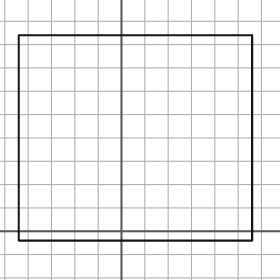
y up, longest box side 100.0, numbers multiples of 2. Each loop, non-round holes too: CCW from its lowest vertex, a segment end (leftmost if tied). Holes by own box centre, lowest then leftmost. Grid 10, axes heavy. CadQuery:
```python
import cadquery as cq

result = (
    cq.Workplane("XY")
    .moveTo(-44.0, -4.0)
    .lineTo(56.0, -4.0)
    .lineTo(56.0, 84.0)
    .lineTo(-44.0, 84.0)
    .close()
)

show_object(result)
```